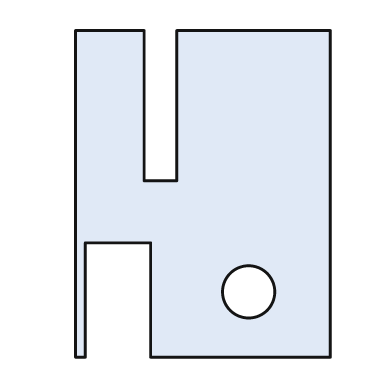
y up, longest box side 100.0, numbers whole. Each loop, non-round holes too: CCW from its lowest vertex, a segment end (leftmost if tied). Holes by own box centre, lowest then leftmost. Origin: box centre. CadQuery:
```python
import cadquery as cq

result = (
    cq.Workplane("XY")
    .moveTo(-39.0, -50.0)
    .lineTo(-36.0, -50.0)
    .lineTo(-36.0, -15.0)
    .lineTo(-16.0, -15.0)
    .lineTo(-16.0, -50.0)
    .lineTo(39.0, -50.0)
    .lineTo(39.0, 50.0)
    .lineTo(-8.0, 50.0)
    .lineTo(-8.0, 4.0)
    .lineTo(-18.0, 4.0)
    .lineTo(-18.0, 50.0)
    .lineTo(-39.0, 50.0)
    .close()
    .moveTo(14.0, -30.0)
    .circle(8.0)
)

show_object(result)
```